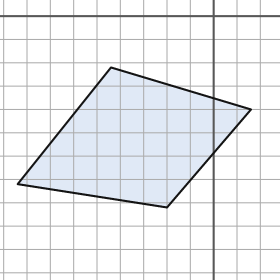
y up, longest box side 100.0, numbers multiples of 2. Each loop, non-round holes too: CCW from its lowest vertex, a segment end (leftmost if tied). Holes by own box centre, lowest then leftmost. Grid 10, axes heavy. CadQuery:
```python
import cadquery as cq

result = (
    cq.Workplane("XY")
    .moveTo(-20.0, -82.0)
    .lineTo(16.0, -40.0)
    .lineTo(-44.0, -22.0)
    .lineTo(-84.0, -72.0)
    .close()
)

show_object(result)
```